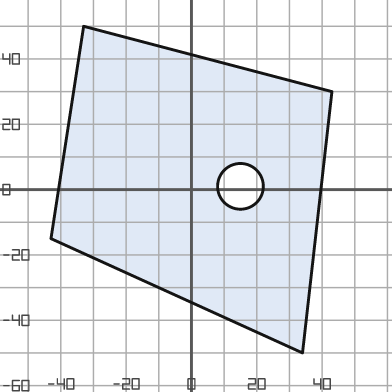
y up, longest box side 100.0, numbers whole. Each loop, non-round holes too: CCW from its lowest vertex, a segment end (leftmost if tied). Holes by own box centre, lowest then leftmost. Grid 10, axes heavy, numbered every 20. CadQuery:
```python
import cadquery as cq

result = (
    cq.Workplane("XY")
    .moveTo(34.0, -50.0)
    .lineTo(43.0, 30.0)
    .lineTo(-33.0, 50.0)
    .lineTo(-43.0, -15.0)
    .close()
    .moveTo(15.0, 1.0)
    .circle(7.0)
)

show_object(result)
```